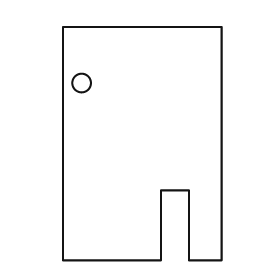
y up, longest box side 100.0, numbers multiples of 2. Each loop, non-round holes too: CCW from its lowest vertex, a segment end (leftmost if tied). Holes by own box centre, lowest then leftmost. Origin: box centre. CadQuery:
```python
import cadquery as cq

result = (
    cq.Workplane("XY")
    .moveTo(-34.0, -50.0)
    .lineTo(8.0, -50.0)
    .lineTo(8.0, -20.0)
    .lineTo(20.0, -20.0)
    .lineTo(20.0, -50.0)
    .lineTo(34.0, -50.0)
    .lineTo(34.0, 50.0)
    .lineTo(-34.0, 50.0)
    .close()
    .moveTo(-26.0, 26.0)
    .circle(4.0)
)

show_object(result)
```